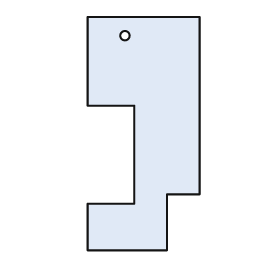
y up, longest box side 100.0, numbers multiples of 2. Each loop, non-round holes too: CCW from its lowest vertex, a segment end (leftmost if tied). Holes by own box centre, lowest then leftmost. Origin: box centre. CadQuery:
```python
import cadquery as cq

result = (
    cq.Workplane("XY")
    .moveTo(-24.0, -50.0)
    .lineTo(10.0, -50.0)
    .lineTo(10.0, -26.0)
    .lineTo(24.0, -26.0)
    .lineTo(24.0, 50.0)
    .lineTo(-24.0, 50.0)
    .lineTo(-24.0, 12.0)
    .lineTo(-4.0, 12.0)
    .lineTo(-4.0, -30.0)
    .lineTo(-24.0, -30.0)
    .close()
    .moveTo(-8.0, 42.0)
    .circle(2.0)
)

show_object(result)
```